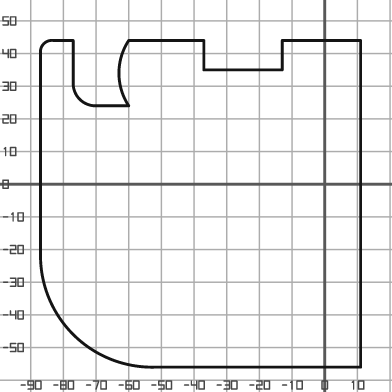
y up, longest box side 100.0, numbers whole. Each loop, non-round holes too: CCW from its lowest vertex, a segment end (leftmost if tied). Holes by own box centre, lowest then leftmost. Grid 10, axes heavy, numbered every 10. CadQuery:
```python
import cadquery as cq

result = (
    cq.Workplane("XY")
    .moveTo(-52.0, -56.0)
    .lineTo(11.0, -56.0)
    .lineTo(11.0, 44.0)
    .lineTo(-13.0, 44.0)
    .lineTo(-13.0, 35.0)
    .lineTo(-37.0, 35.0)
    .lineTo(-37.0, 44.0)
    .lineTo(-60.0, 44.0)
    .threePointArc((-63.0, 34.0), (-60.0, 24.0))
    .lineTo(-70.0, 24.0)
    .threePointArc((-75.0, 26.0), (-77.0, 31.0))
    .lineTo(-77.0, 44.0)
    .lineTo(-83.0, 44.0)
    .threePointArc((-86.0, 43.0), (-87.0, 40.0))
    .lineTo(-87.0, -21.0)
    .threePointArc((-77.0, -46.0), (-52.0, -56.0))
    .close()
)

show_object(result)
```